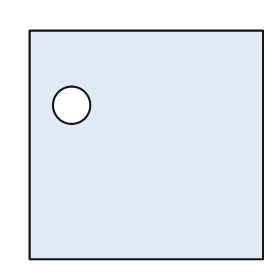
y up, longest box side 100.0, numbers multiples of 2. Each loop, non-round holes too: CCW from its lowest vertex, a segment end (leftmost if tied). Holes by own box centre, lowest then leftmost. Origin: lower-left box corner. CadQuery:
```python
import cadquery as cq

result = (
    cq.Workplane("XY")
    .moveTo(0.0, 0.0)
    .lineTo(100.0, 0.0)
    .lineTo(100.0, 98.0)
    .lineTo(0.0, 98.0)
    .close()
    .moveTo(18.0, 66.0)
    .circle(8.0)
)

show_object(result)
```